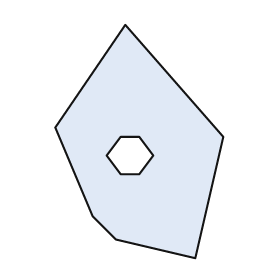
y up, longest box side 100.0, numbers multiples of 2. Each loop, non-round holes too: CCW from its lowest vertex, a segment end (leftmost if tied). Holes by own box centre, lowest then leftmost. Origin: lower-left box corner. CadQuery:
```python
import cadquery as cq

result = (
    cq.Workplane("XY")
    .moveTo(60.0, 0.0)
    .lineTo(72.0, 52.0)
    .lineTo(30.0, 100.0)
    .lineTo(0.0, 56.0)
    .lineTo(16.0, 18.0)
    .lineTo(26.0, 8.0)
    .close()
    .moveTo(28.0, 36.0)
    .lineTo(36.0, 36.0)
    .lineTo(42.0, 44.0)
    .lineTo(36.0, 52.0)
    .lineTo(28.0, 52.0)
    .lineTo(22.0, 44.0)
    .close()
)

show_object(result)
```